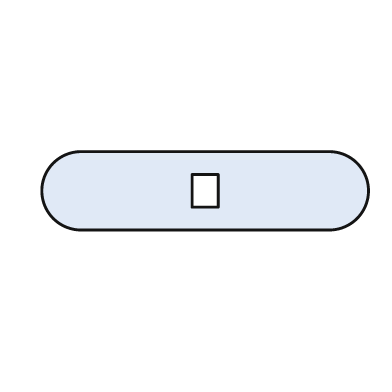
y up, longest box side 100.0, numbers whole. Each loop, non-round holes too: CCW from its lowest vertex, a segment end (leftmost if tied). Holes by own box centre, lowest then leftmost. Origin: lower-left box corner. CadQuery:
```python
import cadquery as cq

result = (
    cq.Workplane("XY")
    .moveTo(12.0, 0.0)
    .lineTo(88.0, 0.0)
    .threePointArc((100.0, 12.0), (88.0, 24.0))
    .lineTo(12.0, 24.0)
    .threePointArc((0.0, 12.0), (12.0, 0.0))
    .close()
    .moveTo(46.0, 7.0)
    .lineTo(54.0, 7.0)
    .lineTo(54.0, 17.0)
    .lineTo(46.0, 17.0)
    .close()
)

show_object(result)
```